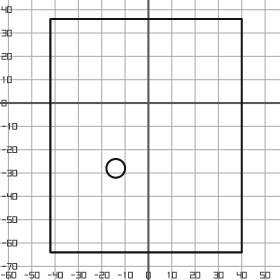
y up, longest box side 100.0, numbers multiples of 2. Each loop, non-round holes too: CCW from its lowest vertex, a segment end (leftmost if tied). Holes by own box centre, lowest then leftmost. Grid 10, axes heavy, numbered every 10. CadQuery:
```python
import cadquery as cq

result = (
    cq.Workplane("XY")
    .moveTo(-42.0, -64.0)
    .lineTo(40.0, -64.0)
    .lineTo(40.0, 36.0)
    .lineTo(-42.0, 36.0)
    .close()
    .moveTo(-14.0, -28.0)
    .circle(4.0)
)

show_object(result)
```